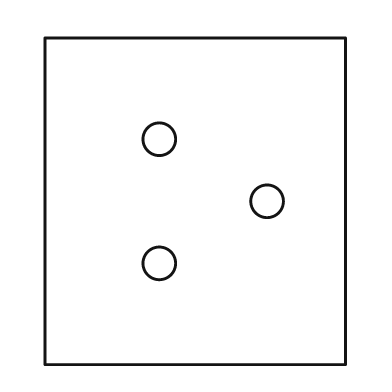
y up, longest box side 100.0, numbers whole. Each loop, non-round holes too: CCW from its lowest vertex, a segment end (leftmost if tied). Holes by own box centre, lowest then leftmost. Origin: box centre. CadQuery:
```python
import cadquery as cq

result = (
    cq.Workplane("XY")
    .moveTo(-46.0, -50.0)
    .lineTo(46.0, -50.0)
    .lineTo(46.0, 50.0)
    .lineTo(-46.0, 50.0)
    .close()
    .moveTo(-11.0, -19.0)
    .circle(5.0)
    .moveTo(22.0, 0.0)
    .circle(5.0)
    .moveTo(-11.0, 19.0)
    .circle(5.0)
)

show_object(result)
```